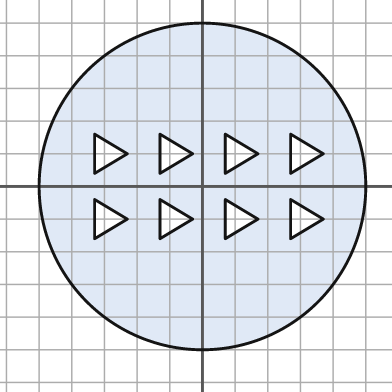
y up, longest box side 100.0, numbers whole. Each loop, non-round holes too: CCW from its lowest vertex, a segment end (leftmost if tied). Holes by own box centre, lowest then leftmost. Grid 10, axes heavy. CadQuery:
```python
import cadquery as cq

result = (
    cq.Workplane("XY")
    .moveTo(0.0, 0.0)
    .circle(50.0)
    .moveTo(-33.0, -16.0)
    .lineTo(-23.0, -10.0)
    .lineTo(-33.0, -4.0)
    .close()
    .moveTo(-13.0, -16.0)
    .lineTo(-3.0, -10.0)
    .lineTo(-13.0, -4.0)
    .close()
    .moveTo(7.0, -16.0)
    .lineTo(17.0, -10.0)
    .lineTo(7.0, -4.0)
    .close()
    .moveTo(27.0, -16.0)
    .lineTo(37.0, -10.0)
    .lineTo(27.0, -4.0)
    .close()
    .moveTo(-33.0, 4.0)
    .lineTo(-23.0, 10.0)
    .lineTo(-33.0, 16.0)
    .close()
    .moveTo(-13.0, 4.0)
    .lineTo(-3.0, 10.0)
    .lineTo(-13.0, 16.0)
    .close()
    .moveTo(7.0, 4.0)
    .lineTo(17.0, 10.0)
    .lineTo(7.0, 16.0)
    .close()
    .moveTo(27.0, 4.0)
    .lineTo(37.0, 10.0)
    .lineTo(27.0, 16.0)
    .close()
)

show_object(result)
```